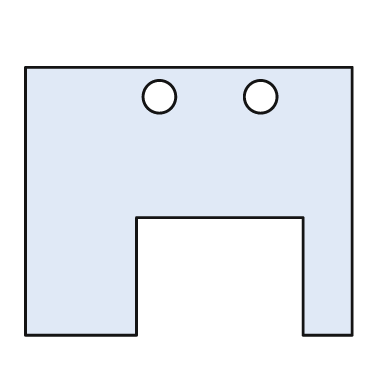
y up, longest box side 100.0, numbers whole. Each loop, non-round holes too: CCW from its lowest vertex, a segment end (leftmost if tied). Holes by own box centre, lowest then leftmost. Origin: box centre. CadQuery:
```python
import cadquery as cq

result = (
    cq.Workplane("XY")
    .moveTo(-50.0, -41.0)
    .lineTo(-16.0, -41.0)
    .lineTo(-16.0, -5.0)
    .lineTo(35.0, -5.0)
    .lineTo(35.0, -41.0)
    .lineTo(50.0, -41.0)
    .lineTo(50.0, 41.0)
    .lineTo(-50.0, 41.0)
    .close()
    .moveTo(-9.0, 32.0)
    .circle(5.0)
    .moveTo(22.0, 32.0)
    .circle(5.0)
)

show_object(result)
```